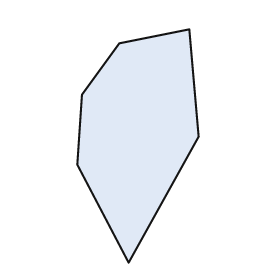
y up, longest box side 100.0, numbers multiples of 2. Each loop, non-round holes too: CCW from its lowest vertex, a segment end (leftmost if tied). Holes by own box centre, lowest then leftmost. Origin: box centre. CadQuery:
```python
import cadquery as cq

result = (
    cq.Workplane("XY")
    .moveTo(-4.0, -50.0)
    .lineTo(26.0, 4.0)
    .lineTo(22.0, 50.0)
    .lineTo(-8.0, 44.0)
    .lineTo(-24.0, 22.0)
    .lineTo(-26.0, -8.0)
    .close()
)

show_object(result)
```